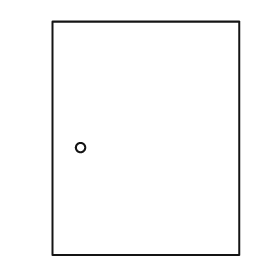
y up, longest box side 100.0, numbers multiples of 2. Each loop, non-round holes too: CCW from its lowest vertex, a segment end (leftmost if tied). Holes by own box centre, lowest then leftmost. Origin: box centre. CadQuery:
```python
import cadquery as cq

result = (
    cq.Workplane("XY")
    .moveTo(-40.0, -50.0)
    .lineTo(40.0, -50.0)
    .lineTo(40.0, 50.0)
    .lineTo(-40.0, 50.0)
    .close()
    .moveTo(-28.0, -4.0)
    .circle(2.0)
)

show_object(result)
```